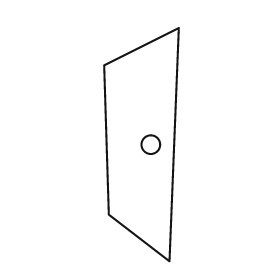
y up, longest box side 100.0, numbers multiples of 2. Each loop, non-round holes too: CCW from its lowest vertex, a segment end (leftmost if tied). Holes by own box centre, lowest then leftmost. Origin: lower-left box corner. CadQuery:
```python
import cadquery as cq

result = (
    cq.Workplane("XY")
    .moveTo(28.0, 0.0)
    .lineTo(32.0, 100.0)
    .lineTo(0.0, 84.0)
    .lineTo(2.0, 20.0)
    .close()
    .moveTo(20.0, 50.0)
    .circle(4.0)
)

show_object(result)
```